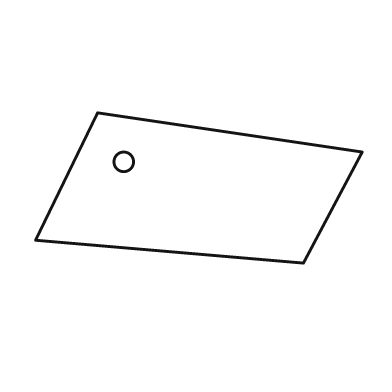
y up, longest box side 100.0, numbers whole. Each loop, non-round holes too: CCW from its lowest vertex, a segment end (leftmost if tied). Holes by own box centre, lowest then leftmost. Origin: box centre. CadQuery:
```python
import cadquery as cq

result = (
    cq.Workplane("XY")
    .moveTo(32.0, -23.0)
    .lineTo(50.0, 11.0)
    .lineTo(-31.0, 23.0)
    .lineTo(-50.0, -16.0)
    .close()
    .moveTo(-23.0, 8.0)
    .circle(3.0)
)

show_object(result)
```